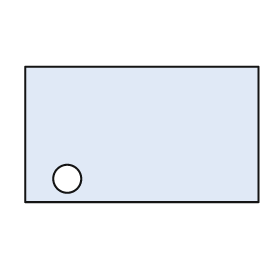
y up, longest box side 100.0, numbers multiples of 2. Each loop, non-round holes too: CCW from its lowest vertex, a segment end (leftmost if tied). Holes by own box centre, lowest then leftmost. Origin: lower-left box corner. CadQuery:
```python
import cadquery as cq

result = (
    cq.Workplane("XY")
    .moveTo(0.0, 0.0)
    .lineTo(100.0, 0.0)
    .lineTo(100.0, 58.0)
    .lineTo(0.0, 58.0)
    .close()
    .moveTo(18.0, 10.0)
    .circle(6.0)
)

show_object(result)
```